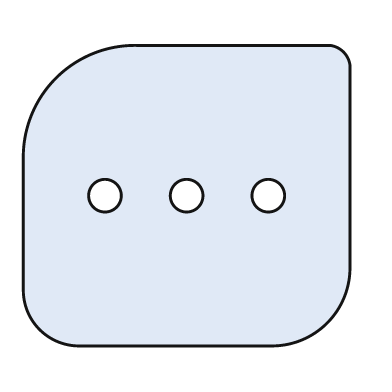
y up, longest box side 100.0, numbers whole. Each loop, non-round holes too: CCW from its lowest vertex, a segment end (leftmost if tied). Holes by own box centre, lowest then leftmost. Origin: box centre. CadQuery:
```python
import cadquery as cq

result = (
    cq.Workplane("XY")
    .moveTo(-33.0, -46.0)
    .lineTo(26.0, -46.0)
    .threePointArc((43.0, -39.0), (50.0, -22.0))
    .lineTo(50.0, 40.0)
    .threePointArc((48.0, 44.0), (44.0, 46.0))
    .lineTo(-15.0, 46.0)
    .threePointArc((-40.0, 36.0), (-50.0, 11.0))
    .lineTo(-50.0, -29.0)
    .threePointArc((-45.0, -41.0), (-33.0, -46.0))
    .close()
    .moveTo(-25.0, 0.0)
    .circle(5.0)
    .moveTo(0.0, 0.0)
    .circle(5.0)
    .moveTo(25.0, 0.0)
    .circle(5.0)
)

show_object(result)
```